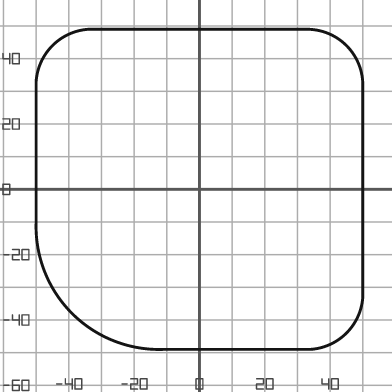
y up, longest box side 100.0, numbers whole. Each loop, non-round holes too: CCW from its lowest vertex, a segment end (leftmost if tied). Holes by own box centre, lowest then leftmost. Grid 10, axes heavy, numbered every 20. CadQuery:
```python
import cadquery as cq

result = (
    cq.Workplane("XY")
    .moveTo(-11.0, -49.0)
    .lineTo(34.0, -49.0)
    .threePointArc((45.0, -44.0), (50.0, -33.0))
    .lineTo(50.0, 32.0)
    .threePointArc((45.0, 44.0), (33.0, 49.0))
    .lineTo(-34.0, 49.0)
    .threePointArc((-45.0, 44.0), (-50.0, 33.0))
    .lineTo(-50.0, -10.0)
    .threePointArc((-39.0, -38.0), (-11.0, -49.0))
    .close()
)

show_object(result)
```